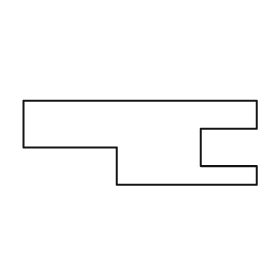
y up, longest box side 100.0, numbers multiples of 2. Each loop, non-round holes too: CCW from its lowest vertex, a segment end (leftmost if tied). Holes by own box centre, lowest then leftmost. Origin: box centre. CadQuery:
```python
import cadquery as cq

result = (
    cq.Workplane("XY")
    .moveTo(-10.0, -18.0)
    .lineTo(50.0, -18.0)
    .lineTo(50.0, -10.0)
    .lineTo(26.0, -10.0)
    .lineTo(26.0, 6.0)
    .lineTo(50.0, 6.0)
    .lineTo(50.0, 18.0)
    .lineTo(-50.0, 18.0)
    .lineTo(-50.0, -2.0)
    .lineTo(-10.0, -2.0)
    .close()
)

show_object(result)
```